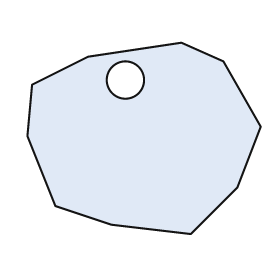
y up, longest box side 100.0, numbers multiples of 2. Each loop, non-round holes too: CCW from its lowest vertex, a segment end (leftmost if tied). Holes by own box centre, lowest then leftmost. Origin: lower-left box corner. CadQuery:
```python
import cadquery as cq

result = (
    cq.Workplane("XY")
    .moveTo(70.0, 0.0)
    .lineTo(90.0, 20.0)
    .lineTo(100.0, 46.0)
    .lineTo(84.0, 74.0)
    .lineTo(66.0, 82.0)
    .lineTo(26.0, 76.0)
    .lineTo(2.0, 64.0)
    .lineTo(0.0, 42.0)
    .lineTo(12.0, 12.0)
    .lineTo(36.0, 4.0)
    .close()
    .moveTo(42.0, 66.0)
    .circle(8.0)
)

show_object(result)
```